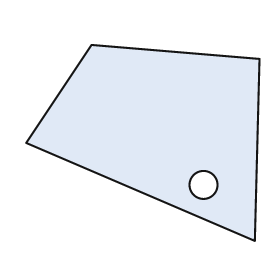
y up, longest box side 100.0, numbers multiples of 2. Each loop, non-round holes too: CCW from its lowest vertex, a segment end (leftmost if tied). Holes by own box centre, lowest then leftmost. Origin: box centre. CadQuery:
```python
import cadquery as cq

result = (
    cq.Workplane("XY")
    .moveTo(48.0, -42.0)
    .lineTo(50.0, 36.0)
    .lineTo(-22.0, 42.0)
    .lineTo(-50.0, 0.0)
    .close()
    .moveTo(26.0, -18.0)
    .circle(6.0)
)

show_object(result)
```